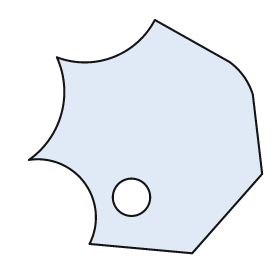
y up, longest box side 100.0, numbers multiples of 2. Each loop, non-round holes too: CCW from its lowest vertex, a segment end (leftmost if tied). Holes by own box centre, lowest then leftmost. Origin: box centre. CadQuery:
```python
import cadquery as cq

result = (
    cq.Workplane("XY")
    .moveTo(20.0, -50.0)
    .lineTo(50.0, -16.0)
    .lineTo(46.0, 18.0)
    .threePointArc((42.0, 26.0), (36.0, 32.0))
    .lineTo(4.0, 50.0)
    .threePointArc((-14.0, 34.0), (-38.0, 34.0))
    .threePointArc((-36.0, 10.0), (-50.0, -10.0))
    .threePointArc((-26.0, -20.0), (-24.0, -46.0))
    .close()
    .moveTo(-6.0, -26.0)
    .circle(8.0)
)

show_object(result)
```